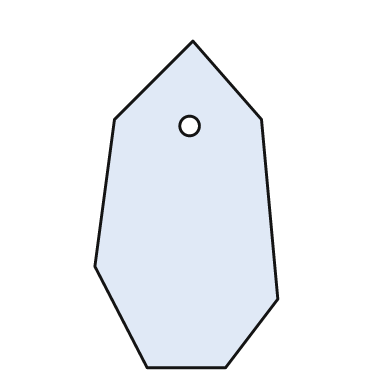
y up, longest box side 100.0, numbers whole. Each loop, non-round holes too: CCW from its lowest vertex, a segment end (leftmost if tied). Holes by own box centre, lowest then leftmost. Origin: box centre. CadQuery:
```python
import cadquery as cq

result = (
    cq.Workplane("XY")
    .moveTo(-12.0, -50.0)
    .lineTo(12.0, -50.0)
    .lineTo(28.0, -29.0)
    .lineTo(23.0, 26.0)
    .lineTo(2.0, 50.0)
    .lineTo(-22.0, 26.0)
    .lineTo(-28.0, -19.0)
    .close()
    .moveTo(1.0, 24.0)
    .circle(3.0)
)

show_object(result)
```